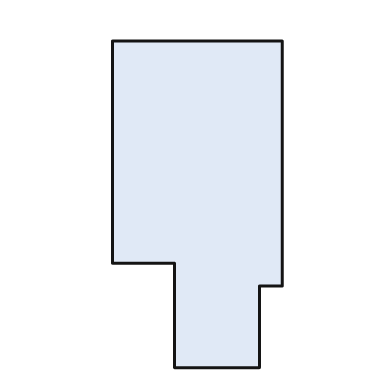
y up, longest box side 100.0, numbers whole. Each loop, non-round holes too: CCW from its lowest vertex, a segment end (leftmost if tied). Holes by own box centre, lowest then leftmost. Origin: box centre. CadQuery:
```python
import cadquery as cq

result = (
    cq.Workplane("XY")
    .moveTo(-7.0, -50.0)
    .lineTo(19.0, -50.0)
    .lineTo(19.0, -25.0)
    .lineTo(26.0, -25.0)
    .lineTo(26.0, 50.0)
    .lineTo(-26.0, 50.0)
    .lineTo(-26.0, -18.0)
    .lineTo(-7.0, -18.0)
    .close()
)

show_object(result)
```